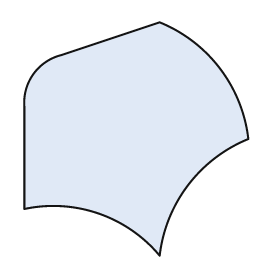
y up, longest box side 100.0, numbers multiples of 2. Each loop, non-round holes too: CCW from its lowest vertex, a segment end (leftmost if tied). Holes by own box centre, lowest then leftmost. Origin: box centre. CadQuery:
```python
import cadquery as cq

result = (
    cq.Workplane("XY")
    .moveTo(10.0, -50.0)
    .threePointArc((22.0, -20.0), (48.0, 0.0))
    .threePointArc((36.0, 30.0), (10.0, 50.0))
    .lineTo(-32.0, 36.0)
    .threePointArc((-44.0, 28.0), (-48.0, 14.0))
    .lineTo(-48.0, -30.0)
    .threePointArc((-16.0, -32.0), (10.0, -50.0))
    .close()
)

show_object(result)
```